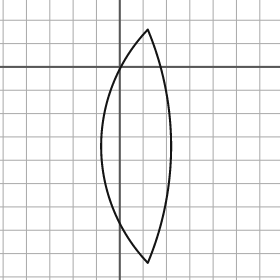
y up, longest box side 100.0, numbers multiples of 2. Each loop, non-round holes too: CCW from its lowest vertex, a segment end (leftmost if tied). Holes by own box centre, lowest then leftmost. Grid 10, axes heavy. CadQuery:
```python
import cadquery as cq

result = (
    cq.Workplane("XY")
    .moveTo(12.0, -84.0)
    .threePointArc((22.0, -34.0), (12.0, 16.0))
    .threePointArc((-8.0, -34.0), (12.0, -84.0))
    .close()
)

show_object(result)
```